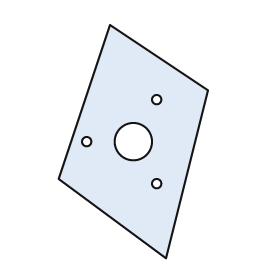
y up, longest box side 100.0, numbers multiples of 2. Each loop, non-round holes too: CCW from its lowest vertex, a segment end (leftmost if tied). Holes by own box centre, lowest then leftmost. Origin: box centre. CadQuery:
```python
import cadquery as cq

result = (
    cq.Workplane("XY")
    .moveTo(14.0, -50.0)
    .lineTo(32.0, 22.0)
    .lineTo(-10.0, 50.0)
    .lineTo(-32.0, -16.0)
    .close()
    .moveTo(10.0, -18.0)
    .circle(2.0)
    .moveTo(-20.0, 0.0)
    .circle(2.0)
    .moveTo(0.0, 0.0)
    .circle(8.0)
    .moveTo(10.0, 18.0)
    .circle(2.0)
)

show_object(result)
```